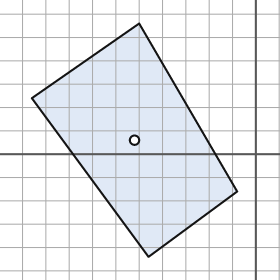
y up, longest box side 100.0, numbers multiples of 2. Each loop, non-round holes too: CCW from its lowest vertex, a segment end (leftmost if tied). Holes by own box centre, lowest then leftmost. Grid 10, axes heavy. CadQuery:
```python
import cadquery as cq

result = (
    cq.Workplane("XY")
    .moveTo(-46.0, -44.0)
    .lineTo(-8.0, -16.0)
    .lineTo(-50.0, 56.0)
    .lineTo(-96.0, 24.0)
    .close()
    .moveTo(-52.0, 6.0)
    .circle(2.0)
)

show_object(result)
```